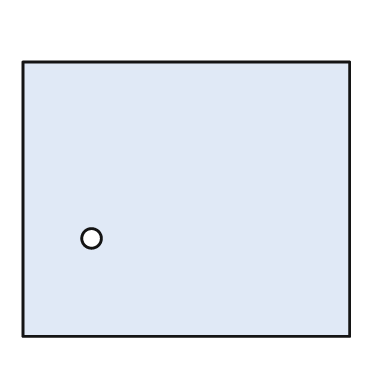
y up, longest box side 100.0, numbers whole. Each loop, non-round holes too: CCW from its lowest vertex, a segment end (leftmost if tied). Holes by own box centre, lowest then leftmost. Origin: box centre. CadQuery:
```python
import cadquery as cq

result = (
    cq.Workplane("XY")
    .moveTo(-50.0, -42.0)
    .lineTo(50.0, -42.0)
    .lineTo(50.0, 42.0)
    .lineTo(-50.0, 42.0)
    .close()
    .moveTo(-29.0, -12.0)
    .circle(3.0)
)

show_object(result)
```